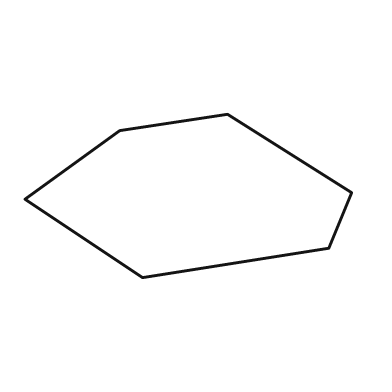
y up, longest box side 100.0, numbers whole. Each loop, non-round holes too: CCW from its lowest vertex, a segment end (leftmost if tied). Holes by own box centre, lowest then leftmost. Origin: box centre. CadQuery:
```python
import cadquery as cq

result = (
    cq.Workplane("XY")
    .moveTo(-14.0, -25.0)
    .lineTo(43.0, -16.0)
    .lineTo(50.0, 1.0)
    .lineTo(12.0, 25.0)
    .lineTo(-21.0, 20.0)
    .lineTo(-50.0, -1.0)
    .close()
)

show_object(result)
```